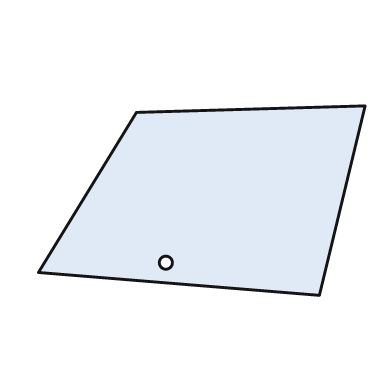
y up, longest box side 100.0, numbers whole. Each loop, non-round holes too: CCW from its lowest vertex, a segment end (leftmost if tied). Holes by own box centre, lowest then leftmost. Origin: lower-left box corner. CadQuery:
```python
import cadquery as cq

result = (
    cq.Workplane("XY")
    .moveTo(86.0, 0.0)
    .lineTo(100.0, 58.0)
    .lineTo(30.0, 56.0)
    .lineTo(0.0, 7.0)
    .close()
    .moveTo(39.0, 10.0)
    .circle(2.0)
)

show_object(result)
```